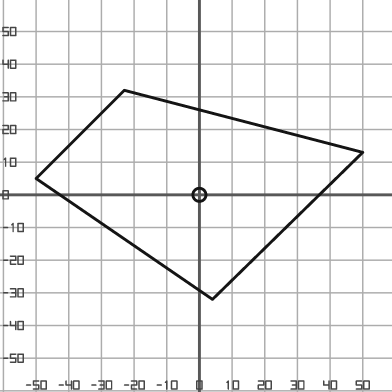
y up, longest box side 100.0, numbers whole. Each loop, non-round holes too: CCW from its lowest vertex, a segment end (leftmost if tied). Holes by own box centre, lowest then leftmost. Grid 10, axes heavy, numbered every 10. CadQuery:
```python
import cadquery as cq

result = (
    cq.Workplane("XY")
    .moveTo(4.0, -32.0)
    .lineTo(50.0, 13.0)
    .lineTo(-23.0, 32.0)
    .lineTo(-50.0, 5.0)
    .close()
    .moveTo(0.0, 0.0)
    .circle(2.0)
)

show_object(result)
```